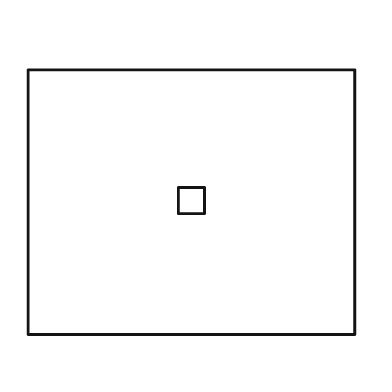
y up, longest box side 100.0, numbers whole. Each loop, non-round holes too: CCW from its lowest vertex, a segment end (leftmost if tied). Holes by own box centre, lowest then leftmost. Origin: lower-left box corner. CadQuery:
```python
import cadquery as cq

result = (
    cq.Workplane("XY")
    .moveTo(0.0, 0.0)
    .lineTo(100.0, 0.0)
    .lineTo(100.0, 81.0)
    .lineTo(0.0, 81.0)
    .close()
    .moveTo(46.0, 37.0)
    .lineTo(54.0, 37.0)
    .lineTo(54.0, 45.0)
    .lineTo(46.0, 45.0)
    .close()
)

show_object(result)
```